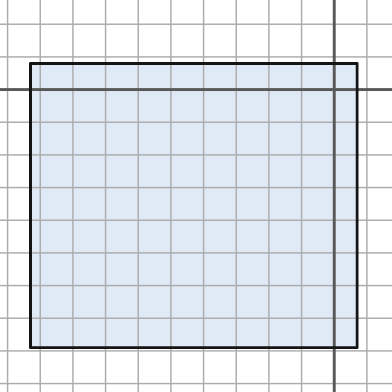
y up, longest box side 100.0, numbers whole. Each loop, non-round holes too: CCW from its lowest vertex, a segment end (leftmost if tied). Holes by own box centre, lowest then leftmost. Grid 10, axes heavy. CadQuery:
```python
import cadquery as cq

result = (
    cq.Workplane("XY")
    .moveTo(-93.0, -79.0)
    .lineTo(7.0, -79.0)
    .lineTo(7.0, 8.0)
    .lineTo(-93.0, 8.0)
    .close()
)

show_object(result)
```